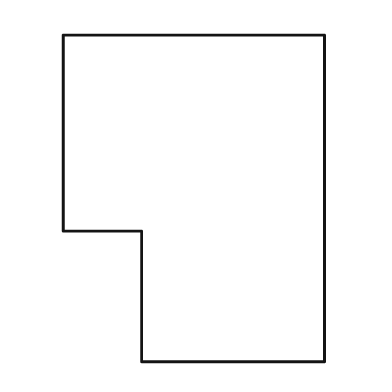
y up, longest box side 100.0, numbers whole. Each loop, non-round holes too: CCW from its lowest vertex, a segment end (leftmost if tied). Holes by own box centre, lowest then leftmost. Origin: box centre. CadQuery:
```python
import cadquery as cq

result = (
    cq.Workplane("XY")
    .moveTo(-16.0, -50.0)
    .lineTo(40.0, -50.0)
    .lineTo(40.0, 50.0)
    .lineTo(-40.0, 50.0)
    .lineTo(-40.0, -10.0)
    .lineTo(-16.0, -10.0)
    .close()
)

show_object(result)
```